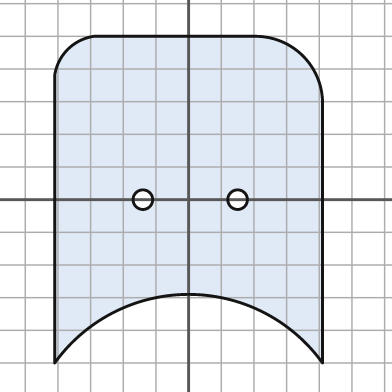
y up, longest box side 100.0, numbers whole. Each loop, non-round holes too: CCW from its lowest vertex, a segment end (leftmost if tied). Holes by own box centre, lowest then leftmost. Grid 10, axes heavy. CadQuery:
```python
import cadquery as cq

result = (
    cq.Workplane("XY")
    .moveTo(-41.0, -50.0)
    .threePointArc((0.0, -29.0), (41.0, -50.0))
    .lineTo(41.0, 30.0)
    .threePointArc((35.0, 44.0), (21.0, 50.0))
    .lineTo(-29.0, 50.0)
    .threePointArc((-37.0, 46.0), (-41.0, 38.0))
    .close()
    .moveTo(-14.0, 0.0)
    .circle(3.0)
    .moveTo(15.0, 0.0)
    .circle(3.0)
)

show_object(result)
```